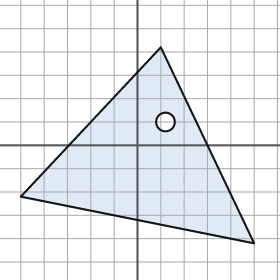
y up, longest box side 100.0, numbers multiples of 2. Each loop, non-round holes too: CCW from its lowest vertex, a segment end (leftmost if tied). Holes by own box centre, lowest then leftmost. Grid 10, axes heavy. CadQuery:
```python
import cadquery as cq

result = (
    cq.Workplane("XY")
    .moveTo(50.0, -42.0)
    .lineTo(10.0, 42.0)
    .lineTo(-50.0, -22.0)
    .close()
    .moveTo(12.0, 10.0)
    .circle(4.0)
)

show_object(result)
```